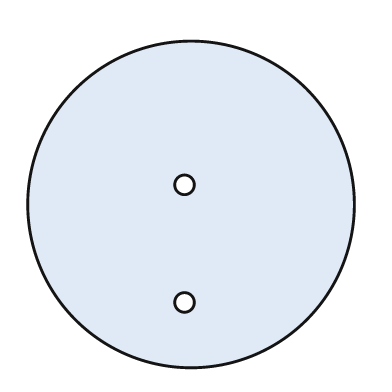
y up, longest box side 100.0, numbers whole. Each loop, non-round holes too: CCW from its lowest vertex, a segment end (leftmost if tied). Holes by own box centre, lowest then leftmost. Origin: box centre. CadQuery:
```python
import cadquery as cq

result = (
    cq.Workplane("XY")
    .moveTo(0.0, 0.0)
    .circle(50.0)
    .moveTo(-2.0, -30.0)
    .circle(3.0)
    .moveTo(-2.0, 6.0)
    .circle(3.0)
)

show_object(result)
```